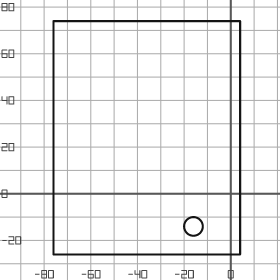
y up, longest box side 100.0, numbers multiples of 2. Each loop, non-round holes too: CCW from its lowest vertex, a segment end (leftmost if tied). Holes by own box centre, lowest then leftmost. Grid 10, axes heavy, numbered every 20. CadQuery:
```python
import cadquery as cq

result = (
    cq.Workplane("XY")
    .moveTo(-76.0, -26.0)
    .lineTo(4.0, -26.0)
    .lineTo(4.0, 74.0)
    .lineTo(-76.0, 74.0)
    .close()
    .moveTo(-16.0, -14.0)
    .circle(4.0)
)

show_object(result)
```